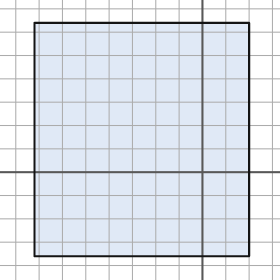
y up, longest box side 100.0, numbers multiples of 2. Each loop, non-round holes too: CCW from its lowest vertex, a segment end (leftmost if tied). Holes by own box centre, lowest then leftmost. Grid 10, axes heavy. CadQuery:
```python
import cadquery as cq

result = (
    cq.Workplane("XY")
    .moveTo(-72.0, -36.0)
    .lineTo(20.0, -36.0)
    .lineTo(20.0, 64.0)
    .lineTo(-72.0, 64.0)
    .close()
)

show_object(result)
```